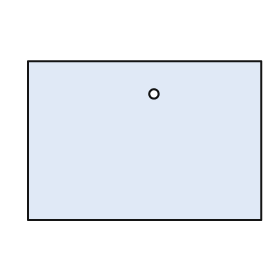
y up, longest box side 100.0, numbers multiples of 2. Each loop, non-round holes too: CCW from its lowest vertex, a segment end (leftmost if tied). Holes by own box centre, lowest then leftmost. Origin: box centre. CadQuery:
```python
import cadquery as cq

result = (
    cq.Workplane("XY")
    .moveTo(-50.0, -34.0)
    .lineTo(50.0, -34.0)
    .lineTo(50.0, 34.0)
    .lineTo(-50.0, 34.0)
    .close()
    .moveTo(4.0, 20.0)
    .circle(2.0)
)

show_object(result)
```